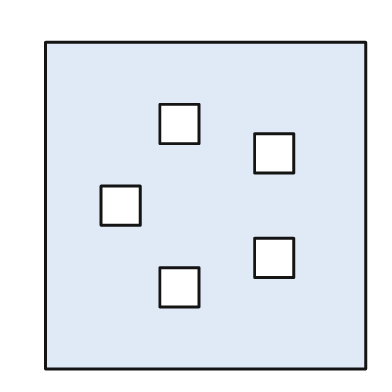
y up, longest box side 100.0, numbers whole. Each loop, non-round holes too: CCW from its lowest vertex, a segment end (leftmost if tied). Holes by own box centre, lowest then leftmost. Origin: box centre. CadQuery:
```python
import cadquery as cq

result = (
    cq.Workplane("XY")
    .moveTo(-49.0, -50.0)
    .lineTo(49.0, -50.0)
    .lineTo(49.0, 50.0)
    .lineTo(-49.0, 50.0)
    .close()
    .moveTo(-14.0, -31.0)
    .lineTo(-2.0, -31.0)
    .lineTo(-2.0, -19.0)
    .lineTo(-14.0, -19.0)
    .close()
    .moveTo(15.0, -22.0)
    .lineTo(27.0, -22.0)
    .lineTo(27.0, -10.0)
    .lineTo(15.0, -10.0)
    .close()
    .moveTo(-32.0, -6.0)
    .lineTo(-20.0, -6.0)
    .lineTo(-20.0, 6.0)
    .lineTo(-32.0, 6.0)
    .close()
    .moveTo(15.0, 10.0)
    .lineTo(27.0, 10.0)
    .lineTo(27.0, 22.0)
    .lineTo(15.0, 22.0)
    .close()
    .moveTo(-14.0, 19.0)
    .lineTo(-2.0, 19.0)
    .lineTo(-2.0, 31.0)
    .lineTo(-14.0, 31.0)
    .close()
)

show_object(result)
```